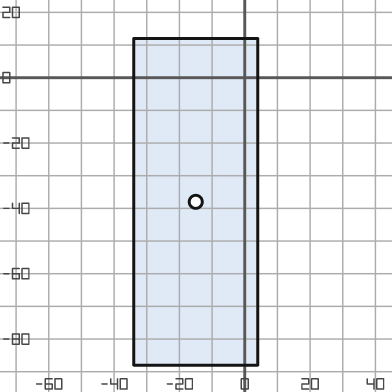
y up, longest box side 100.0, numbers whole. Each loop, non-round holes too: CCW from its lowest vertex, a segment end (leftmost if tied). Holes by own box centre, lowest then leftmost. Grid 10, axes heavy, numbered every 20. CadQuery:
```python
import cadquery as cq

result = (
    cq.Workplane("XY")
    .moveTo(-34.0, -88.0)
    .lineTo(4.0, -88.0)
    .lineTo(4.0, 12.0)
    .lineTo(-34.0, 12.0)
    .close()
    .moveTo(-15.0, -38.0)
    .circle(2.0)
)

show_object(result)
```